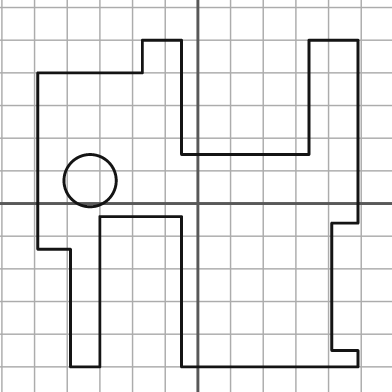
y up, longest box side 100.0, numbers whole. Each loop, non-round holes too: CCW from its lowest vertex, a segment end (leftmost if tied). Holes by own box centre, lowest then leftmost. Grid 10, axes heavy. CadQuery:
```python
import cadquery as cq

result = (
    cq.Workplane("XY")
    .moveTo(-39.0, -50.0)
    .lineTo(-30.0, -50.0)
    .lineTo(-30.0, -4.0)
    .lineTo(-5.0, -4.0)
    .lineTo(-5.0, -50.0)
    .lineTo(49.0, -50.0)
    .lineTo(49.0, -45.0)
    .lineTo(41.0, -45.0)
    .lineTo(41.0, -6.0)
    .lineTo(49.0, -6.0)
    .lineTo(49.0, 50.0)
    .lineTo(34.0, 50.0)
    .lineTo(34.0, 15.0)
    .lineTo(-5.0, 15.0)
    .lineTo(-5.0, 50.0)
    .lineTo(-17.0, 50.0)
    .lineTo(-17.0, 40.0)
    .lineTo(-49.0, 40.0)
    .lineTo(-49.0, -14.0)
    .lineTo(-39.0, -14.0)
    .close()
    .moveTo(-33.0, 7.0)
    .circle(8.0)
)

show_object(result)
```